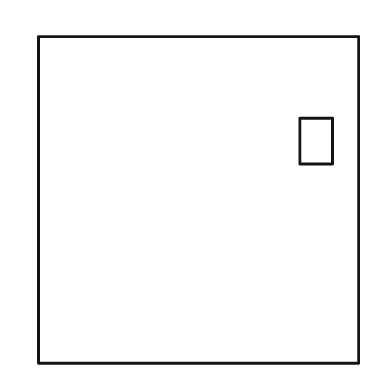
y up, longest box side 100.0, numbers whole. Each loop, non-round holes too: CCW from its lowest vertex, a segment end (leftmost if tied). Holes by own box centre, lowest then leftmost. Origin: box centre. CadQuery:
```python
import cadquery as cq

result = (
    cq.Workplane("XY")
    .moveTo(-49.0, -50.0)
    .lineTo(49.0, -50.0)
    .lineTo(49.0, 50.0)
    .lineTo(-49.0, 50.0)
    .close()
    .moveTo(31.0, 11.0)
    .lineTo(41.0, 11.0)
    .lineTo(41.0, 25.0)
    .lineTo(31.0, 25.0)
    .close()
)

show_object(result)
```